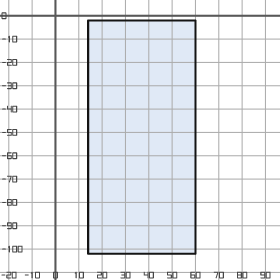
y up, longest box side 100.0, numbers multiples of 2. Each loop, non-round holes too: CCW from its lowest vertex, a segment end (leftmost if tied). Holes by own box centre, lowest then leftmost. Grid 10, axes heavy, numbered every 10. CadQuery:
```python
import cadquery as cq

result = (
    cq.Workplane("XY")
    .moveTo(14.0, -102.0)
    .lineTo(60.0, -102.0)
    .lineTo(60.0, -2.0)
    .lineTo(14.0, -2.0)
    .close()
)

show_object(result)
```